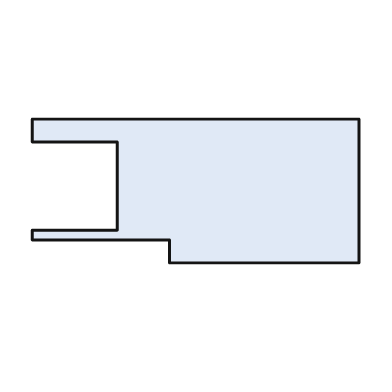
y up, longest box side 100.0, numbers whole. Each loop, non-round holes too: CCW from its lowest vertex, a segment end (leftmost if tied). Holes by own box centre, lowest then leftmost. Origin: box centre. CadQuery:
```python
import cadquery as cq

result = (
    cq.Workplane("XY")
    .moveTo(-8.0, -22.0)
    .lineTo(50.0, -22.0)
    .lineTo(50.0, 22.0)
    .lineTo(-50.0, 22.0)
    .lineTo(-50.0, 15.0)
    .lineTo(-24.0, 15.0)
    .lineTo(-24.0, -12.0)
    .lineTo(-50.0, -12.0)
    .lineTo(-50.0, -15.0)
    .lineTo(-8.0, -15.0)
    .close()
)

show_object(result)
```